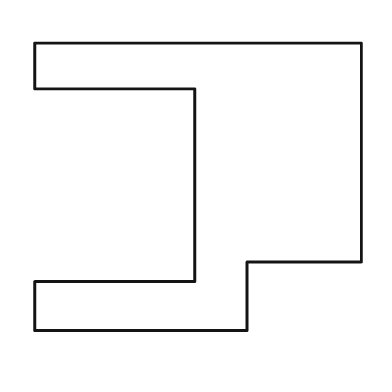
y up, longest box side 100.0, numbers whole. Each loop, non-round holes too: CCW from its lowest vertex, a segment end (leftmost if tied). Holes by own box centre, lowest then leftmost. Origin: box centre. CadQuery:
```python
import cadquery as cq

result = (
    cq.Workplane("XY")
    .moveTo(-50.0, -44.0)
    .lineTo(15.0, -44.0)
    .lineTo(15.0, -23.0)
    .lineTo(50.0, -23.0)
    .lineTo(50.0, 44.0)
    .lineTo(-50.0, 44.0)
    .lineTo(-50.0, 30.0)
    .lineTo(-1.0, 30.0)
    .lineTo(-1.0, -29.0)
    .lineTo(-50.0, -29.0)
    .close()
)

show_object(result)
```